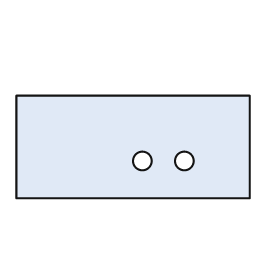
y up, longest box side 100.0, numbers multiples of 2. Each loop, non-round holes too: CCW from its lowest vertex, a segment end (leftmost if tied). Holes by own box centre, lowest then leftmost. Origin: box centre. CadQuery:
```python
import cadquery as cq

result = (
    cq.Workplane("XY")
    .moveTo(-50.0, -22.0)
    .lineTo(50.0, -22.0)
    .lineTo(50.0, 22.0)
    .lineTo(-50.0, 22.0)
    .close()
    .moveTo(4.0, -6.0)
    .circle(4.0)
    .moveTo(22.0, -6.0)
    .circle(4.0)
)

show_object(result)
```